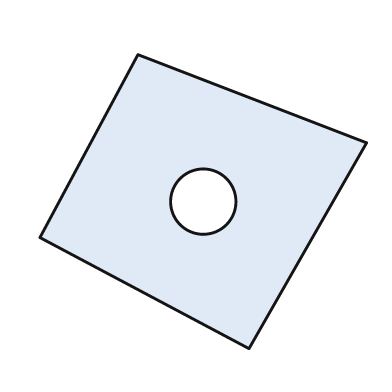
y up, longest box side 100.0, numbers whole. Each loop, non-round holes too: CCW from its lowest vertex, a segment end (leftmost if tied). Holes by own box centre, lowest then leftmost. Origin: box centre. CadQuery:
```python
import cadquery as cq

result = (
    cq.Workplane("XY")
    .moveTo(14.0, -45.0)
    .lineTo(50.0, 18.0)
    .lineTo(-20.0, 45.0)
    .lineTo(-50.0, -11.0)
    .close()
    .moveTo(0.0, 0.0)
    .circle(10.0)
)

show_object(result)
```